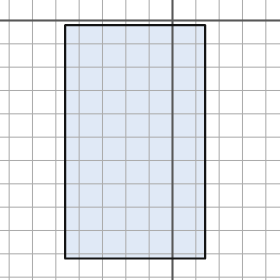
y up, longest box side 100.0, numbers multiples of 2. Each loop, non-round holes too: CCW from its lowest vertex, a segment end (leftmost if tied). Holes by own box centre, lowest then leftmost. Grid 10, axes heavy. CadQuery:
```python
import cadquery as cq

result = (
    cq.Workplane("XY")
    .moveTo(-46.0, -102.0)
    .lineTo(14.0, -102.0)
    .lineTo(14.0, -2.0)
    .lineTo(-46.0, -2.0)
    .close()
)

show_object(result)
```